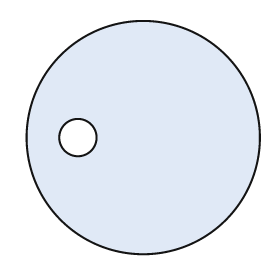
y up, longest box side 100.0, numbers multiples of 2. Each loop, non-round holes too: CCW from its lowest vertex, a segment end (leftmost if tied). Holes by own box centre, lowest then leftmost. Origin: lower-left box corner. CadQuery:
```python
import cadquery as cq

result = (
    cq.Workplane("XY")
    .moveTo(50.0, 50.0)
    .circle(50.0)
    .moveTo(22.0, 50.0)
    .circle(8.0)
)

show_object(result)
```